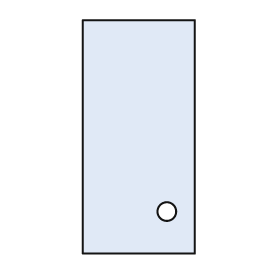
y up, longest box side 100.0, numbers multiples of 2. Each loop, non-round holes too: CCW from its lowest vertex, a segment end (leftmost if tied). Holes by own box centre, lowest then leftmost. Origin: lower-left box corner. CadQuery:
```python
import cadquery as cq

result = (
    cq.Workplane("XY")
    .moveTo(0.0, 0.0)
    .lineTo(48.0, 0.0)
    .lineTo(48.0, 100.0)
    .lineTo(0.0, 100.0)
    .close()
    .moveTo(36.0, 18.0)
    .circle(4.0)
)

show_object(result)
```